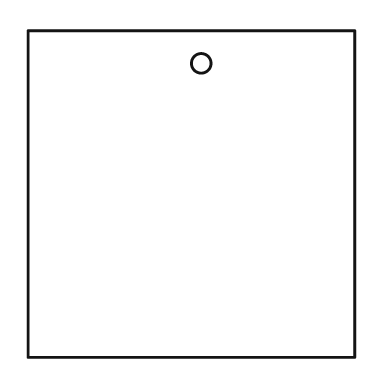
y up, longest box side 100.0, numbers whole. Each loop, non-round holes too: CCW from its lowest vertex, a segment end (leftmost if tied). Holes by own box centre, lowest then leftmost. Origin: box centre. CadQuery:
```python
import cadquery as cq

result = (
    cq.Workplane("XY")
    .moveTo(-50.0, -50.0)
    .lineTo(50.0, -50.0)
    .lineTo(50.0, 50.0)
    .lineTo(-50.0, 50.0)
    .close()
    .moveTo(3.0, 40.0)
    .circle(3.0)
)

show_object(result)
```